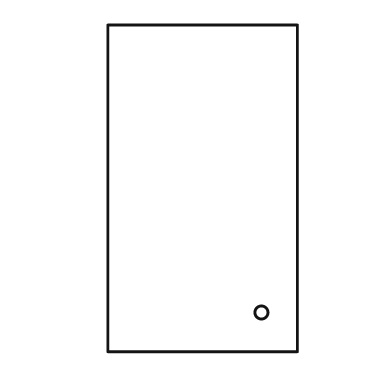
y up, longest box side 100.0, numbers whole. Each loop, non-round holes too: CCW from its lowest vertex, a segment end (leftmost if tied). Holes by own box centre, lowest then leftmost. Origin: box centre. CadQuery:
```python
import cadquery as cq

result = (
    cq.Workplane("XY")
    .moveTo(-29.0, -50.0)
    .lineTo(29.0, -50.0)
    .lineTo(29.0, 50.0)
    .lineTo(-29.0, 50.0)
    .close()
    .moveTo(18.0, -38.0)
    .circle(2.0)
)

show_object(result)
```